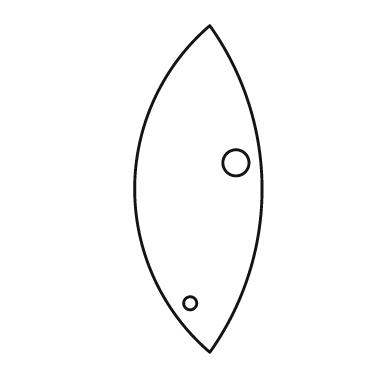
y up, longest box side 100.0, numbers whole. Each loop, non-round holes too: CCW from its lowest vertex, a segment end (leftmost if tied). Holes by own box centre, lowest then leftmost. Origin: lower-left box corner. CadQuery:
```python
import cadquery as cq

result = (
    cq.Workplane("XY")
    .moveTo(23.0, 0.0)
    .threePointArc((39.0, 50.0), (23.0, 100.0))
    .threePointArc((0.0, 50.0), (23.0, 0.0))
    .close()
    .moveTo(17.0, 15.0)
    .circle(2.0)
    .moveTo(31.0, 58.0)
    .circle(4.0)
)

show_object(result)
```